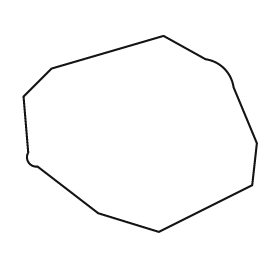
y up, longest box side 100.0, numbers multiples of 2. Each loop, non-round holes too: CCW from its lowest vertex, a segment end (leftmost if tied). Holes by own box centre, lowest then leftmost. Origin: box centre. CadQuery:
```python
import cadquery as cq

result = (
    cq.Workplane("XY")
    .moveTo(8.0, -42.0)
    .lineTo(48.0, -22.0)
    .lineTo(50.0, -4.0)
    .lineTo(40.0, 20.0)
    .threePointArc((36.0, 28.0), (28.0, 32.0))
    .lineTo(10.0, 42.0)
    .lineTo(-38.0, 28.0)
    .lineTo(-50.0, 16.0)
    .lineTo(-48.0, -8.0)
    .threePointArc((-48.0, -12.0), (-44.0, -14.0))
    .lineTo(-18.0, -34.0)
    .close()
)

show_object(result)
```